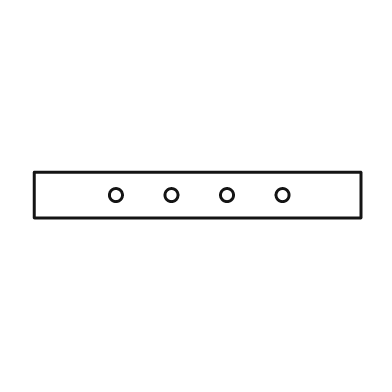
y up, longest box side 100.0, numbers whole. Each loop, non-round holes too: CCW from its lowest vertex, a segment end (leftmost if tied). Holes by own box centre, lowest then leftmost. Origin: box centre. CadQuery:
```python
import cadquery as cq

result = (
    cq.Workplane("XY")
    .moveTo(-50.0, -7.0)
    .lineTo(50.0, -7.0)
    .lineTo(50.0, 7.0)
    .lineTo(-50.0, 7.0)
    .close()
    .moveTo(-25.0, 0.0)
    .circle(2.0)
    .moveTo(-8.0, 0.0)
    .circle(2.0)
    .moveTo(9.0, 0.0)
    .circle(2.0)
    .moveTo(26.0, 0.0)
    .circle(2.0)
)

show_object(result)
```